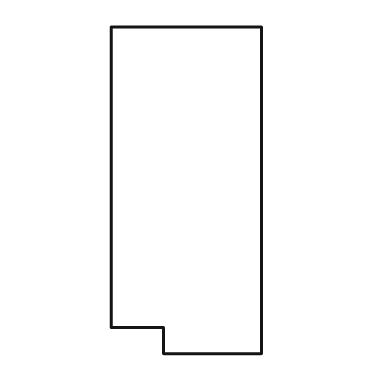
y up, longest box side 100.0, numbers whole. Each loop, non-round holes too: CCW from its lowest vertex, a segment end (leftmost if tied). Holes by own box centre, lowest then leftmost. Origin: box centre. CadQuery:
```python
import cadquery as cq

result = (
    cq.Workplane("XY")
    .moveTo(-7.0, -50.0)
    .lineTo(23.0, -50.0)
    .lineTo(23.0, 50.0)
    .lineTo(-23.0, 50.0)
    .lineTo(-23.0, -42.0)
    .lineTo(-7.0, -42.0)
    .close()
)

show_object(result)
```